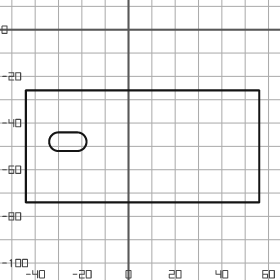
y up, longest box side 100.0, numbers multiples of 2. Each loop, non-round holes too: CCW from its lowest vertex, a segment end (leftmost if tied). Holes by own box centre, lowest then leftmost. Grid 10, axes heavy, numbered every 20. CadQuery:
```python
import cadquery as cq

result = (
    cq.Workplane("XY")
    .moveTo(-44.0, -74.0)
    .lineTo(56.0, -74.0)
    .lineTo(56.0, -26.0)
    .lineTo(-44.0, -26.0)
    .close()
    .moveTo(-30.0, -52.0)
    .lineTo(-22.0, -52.0)
    .threePointArc((-18.0, -48.0), (-22.0, -44.0))
    .lineTo(-30.0, -44.0)
    .threePointArc((-34.0, -48.0), (-30.0, -52.0))
    .close()
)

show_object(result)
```